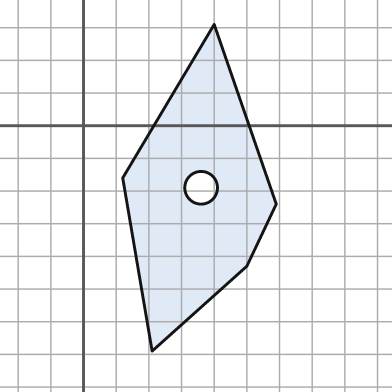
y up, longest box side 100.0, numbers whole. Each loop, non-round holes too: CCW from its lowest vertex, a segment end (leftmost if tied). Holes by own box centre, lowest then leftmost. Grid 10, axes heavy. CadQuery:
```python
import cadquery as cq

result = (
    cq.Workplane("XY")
    .moveTo(21.0, -69.0)
    .lineTo(50.0, -43.0)
    .lineTo(59.0, -24.0)
    .lineTo(40.0, 31.0)
    .lineTo(12.0, -16.0)
    .close()
    .moveTo(36.0, -19.0)
    .circle(5.0)
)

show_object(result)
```